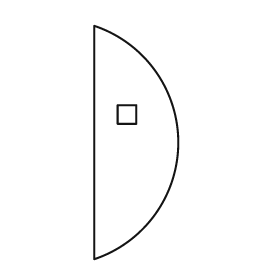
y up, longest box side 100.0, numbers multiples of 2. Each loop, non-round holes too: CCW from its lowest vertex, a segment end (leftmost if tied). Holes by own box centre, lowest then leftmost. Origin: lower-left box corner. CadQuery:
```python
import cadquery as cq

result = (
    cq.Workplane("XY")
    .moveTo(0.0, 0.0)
    .threePointArc((36.0, 50.0), (0.0, 100.0))
    .close()
    .moveTo(10.0, 58.0)
    .lineTo(18.0, 58.0)
    .lineTo(18.0, 66.0)
    .lineTo(10.0, 66.0)
    .close()
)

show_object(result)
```